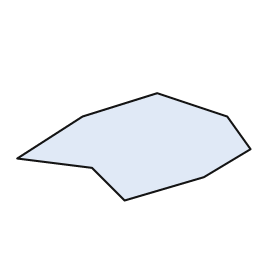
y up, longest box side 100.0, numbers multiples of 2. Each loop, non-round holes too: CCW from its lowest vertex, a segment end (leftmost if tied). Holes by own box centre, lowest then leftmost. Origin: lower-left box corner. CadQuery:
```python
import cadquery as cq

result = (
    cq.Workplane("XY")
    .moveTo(46.0, 0.0)
    .lineTo(80.0, 10.0)
    .lineTo(100.0, 22.0)
    .lineTo(90.0, 36.0)
    .lineTo(60.0, 46.0)
    .lineTo(28.0, 36.0)
    .lineTo(0.0, 18.0)
    .lineTo(32.0, 14.0)
    .close()
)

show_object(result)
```